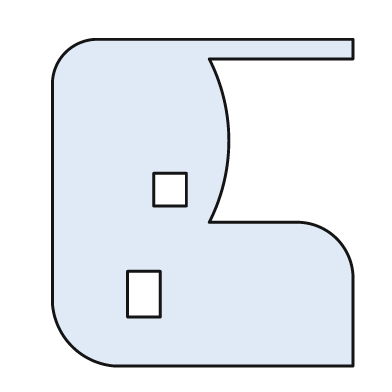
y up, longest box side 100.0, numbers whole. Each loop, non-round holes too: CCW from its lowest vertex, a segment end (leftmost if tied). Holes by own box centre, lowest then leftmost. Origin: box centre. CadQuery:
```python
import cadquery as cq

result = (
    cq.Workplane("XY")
    .moveTo(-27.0, -50.0)
    .lineTo(46.0, -50.0)
    .lineTo(46.0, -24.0)
    .threePointArc((41.0, -11.0), (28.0, -6.0))
    .lineTo(2.0, -6.0)
    .threePointArc((8.0, 19.0), (2.0, 44.0))
    .lineTo(46.0, 44.0)
    .lineTo(46.0, 50.0)
    .lineTo(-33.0, 50.0)
    .threePointArc((-42.0, 46.0), (-46.0, 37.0))
    .lineTo(-46.0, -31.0)
    .threePointArc((-40.0, -44.0), (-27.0, -50.0))
    .close()
    .moveTo(-23.0, -35.0)
    .lineTo(-13.0, -35.0)
    .lineTo(-13.0, -21.0)
    .lineTo(-23.0, -21.0)
    .close()
    .moveTo(-15.0, -1.0)
    .lineTo(-5.0, -1.0)
    .lineTo(-5.0, 9.0)
    .lineTo(-15.0, 9.0)
    .close()
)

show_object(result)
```